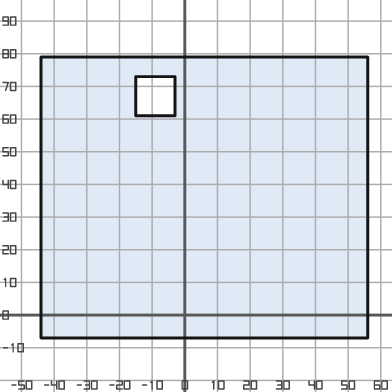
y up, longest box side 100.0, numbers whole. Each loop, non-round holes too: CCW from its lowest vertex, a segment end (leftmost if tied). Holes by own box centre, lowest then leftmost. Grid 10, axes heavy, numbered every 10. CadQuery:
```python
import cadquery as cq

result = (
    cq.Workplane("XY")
    .moveTo(-44.0, -7.0)
    .lineTo(56.0, -7.0)
    .lineTo(56.0, 79.0)
    .lineTo(-44.0, 79.0)
    .close()
    .moveTo(-15.0, 61.0)
    .lineTo(-3.0, 61.0)
    .lineTo(-3.0, 73.0)
    .lineTo(-15.0, 73.0)
    .close()
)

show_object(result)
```